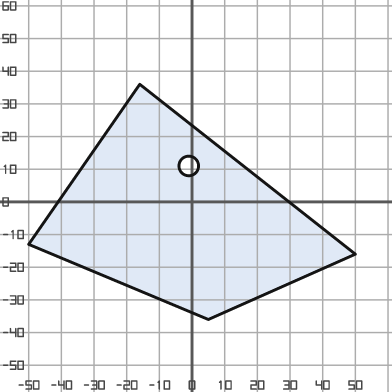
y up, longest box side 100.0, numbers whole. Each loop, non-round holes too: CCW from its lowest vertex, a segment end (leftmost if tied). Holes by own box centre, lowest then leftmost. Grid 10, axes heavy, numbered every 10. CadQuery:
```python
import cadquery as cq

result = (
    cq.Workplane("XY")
    .moveTo(5.0, -36.0)
    .lineTo(50.0, -16.0)
    .lineTo(-16.0, 36.0)
    .lineTo(-50.0, -13.0)
    .close()
    .moveTo(-1.0, 11.0)
    .circle(3.0)
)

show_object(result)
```